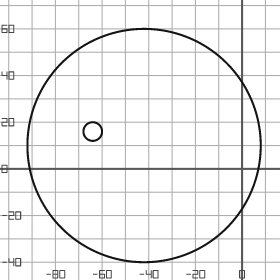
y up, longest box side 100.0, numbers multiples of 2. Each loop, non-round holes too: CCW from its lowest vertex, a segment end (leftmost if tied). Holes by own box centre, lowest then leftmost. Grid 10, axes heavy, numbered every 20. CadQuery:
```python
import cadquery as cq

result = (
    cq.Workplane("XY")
    .moveTo(-42.0, 10.0)
    .circle(50.0)
    .moveTo(-64.0, 16.0)
    .circle(4.0)
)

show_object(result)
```